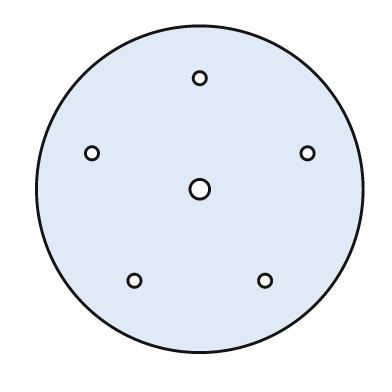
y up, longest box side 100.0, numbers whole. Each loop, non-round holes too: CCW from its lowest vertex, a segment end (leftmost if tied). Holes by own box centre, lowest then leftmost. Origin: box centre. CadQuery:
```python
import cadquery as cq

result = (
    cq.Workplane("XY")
    .moveTo(0.0, 0.0)
    .circle(50.0)
    .moveTo(-20.0, -28.0)
    .circle(2.0)
    .moveTo(20.0, -28.0)
    .circle(2.0)
    .moveTo(0.0, 0.0)
    .circle(3.0)
    .moveTo(-33.0, 11.0)
    .circle(2.0)
    .moveTo(33.0, 11.0)
    .circle(2.0)
    .moveTo(0.0, 34.0)
    .circle(2.0)
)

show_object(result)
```